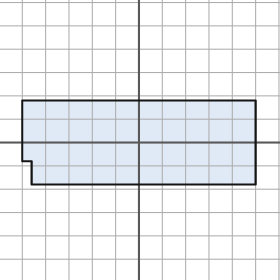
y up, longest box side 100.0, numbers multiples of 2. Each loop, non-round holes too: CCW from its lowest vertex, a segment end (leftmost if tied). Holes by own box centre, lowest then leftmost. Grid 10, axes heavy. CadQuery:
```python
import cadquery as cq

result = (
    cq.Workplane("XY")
    .moveTo(-46.0, -18.0)
    .lineTo(50.0, -18.0)
    .lineTo(50.0, 18.0)
    .lineTo(-50.0, 18.0)
    .lineTo(-50.0, -8.0)
    .lineTo(-46.0, -8.0)
    .close()
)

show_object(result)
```